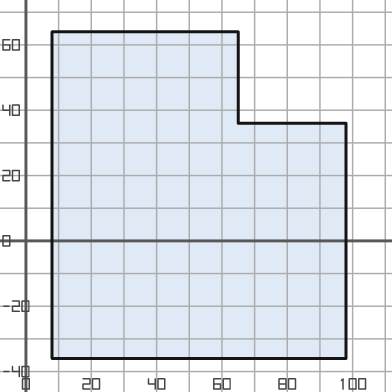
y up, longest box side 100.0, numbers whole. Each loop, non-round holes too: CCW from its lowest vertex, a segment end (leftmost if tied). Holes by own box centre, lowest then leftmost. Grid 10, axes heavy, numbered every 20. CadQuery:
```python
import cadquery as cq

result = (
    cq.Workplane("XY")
    .moveTo(8.0, -36.0)
    .lineTo(98.0, -36.0)
    .lineTo(98.0, 36.0)
    .lineTo(65.0, 36.0)
    .lineTo(65.0, 64.0)
    .lineTo(8.0, 64.0)
    .close()
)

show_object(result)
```